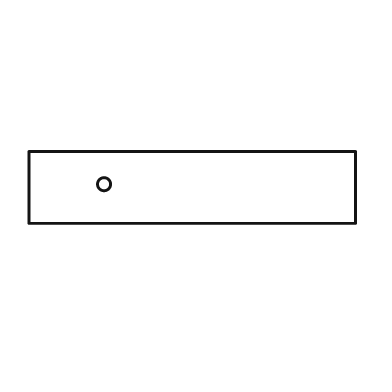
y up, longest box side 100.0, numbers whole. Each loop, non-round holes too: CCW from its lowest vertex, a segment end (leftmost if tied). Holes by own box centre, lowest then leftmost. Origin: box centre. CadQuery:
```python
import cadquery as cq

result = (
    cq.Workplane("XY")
    .moveTo(-50.0, -11.0)
    .lineTo(50.0, -11.0)
    .lineTo(50.0, 11.0)
    .lineTo(-50.0, 11.0)
    .close()
    .moveTo(-27.0, 1.0)
    .circle(2.0)
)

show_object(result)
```